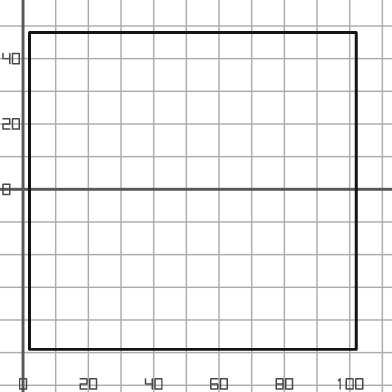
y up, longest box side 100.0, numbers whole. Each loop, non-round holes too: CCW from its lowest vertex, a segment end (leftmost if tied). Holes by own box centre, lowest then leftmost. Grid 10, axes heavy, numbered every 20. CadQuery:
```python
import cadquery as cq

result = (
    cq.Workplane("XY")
    .moveTo(2.0, -49.0)
    .lineTo(102.0, -49.0)
    .lineTo(102.0, 48.0)
    .lineTo(2.0, 48.0)
    .close()
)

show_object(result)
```